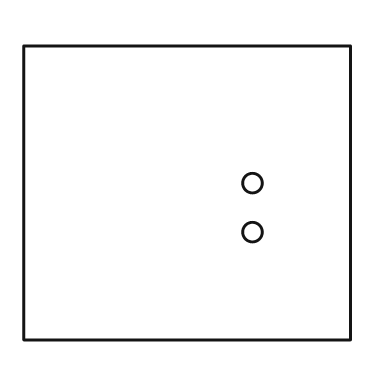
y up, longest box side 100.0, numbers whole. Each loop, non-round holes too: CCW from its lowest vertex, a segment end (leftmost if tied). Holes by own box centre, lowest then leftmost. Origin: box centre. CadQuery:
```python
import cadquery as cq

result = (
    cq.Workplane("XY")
    .moveTo(-50.0, -45.0)
    .lineTo(50.0, -45.0)
    .lineTo(50.0, 45.0)
    .lineTo(-50.0, 45.0)
    .close()
    .moveTo(20.0, -12.0)
    .circle(3.0)
    .moveTo(20.0, 3.0)
    .circle(3.0)
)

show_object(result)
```